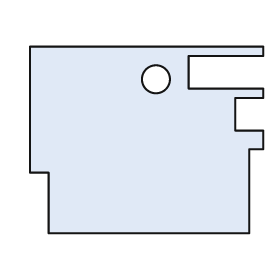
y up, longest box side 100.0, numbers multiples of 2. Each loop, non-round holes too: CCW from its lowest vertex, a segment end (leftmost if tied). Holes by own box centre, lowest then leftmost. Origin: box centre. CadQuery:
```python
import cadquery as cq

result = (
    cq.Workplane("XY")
    .moveTo(-42.0, -40.0)
    .lineTo(44.0, -40.0)
    .lineTo(44.0, -4.0)
    .lineTo(50.0, -4.0)
    .lineTo(50.0, 4.0)
    .lineTo(38.0, 4.0)
    .lineTo(38.0, 18.0)
    .lineTo(50.0, 18.0)
    .lineTo(50.0, 22.0)
    .lineTo(18.0, 22.0)
    .lineTo(18.0, 36.0)
    .lineTo(50.0, 36.0)
    .lineTo(50.0, 40.0)
    .lineTo(-50.0, 40.0)
    .lineTo(-50.0, -14.0)
    .lineTo(-42.0, -14.0)
    .close()
    .moveTo(4.0, 26.0)
    .circle(6.0)
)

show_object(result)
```